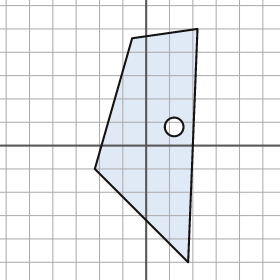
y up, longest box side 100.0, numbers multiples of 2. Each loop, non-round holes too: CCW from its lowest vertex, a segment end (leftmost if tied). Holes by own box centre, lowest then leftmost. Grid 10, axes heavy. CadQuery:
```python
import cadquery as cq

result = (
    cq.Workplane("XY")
    .moveTo(18.0, -50.0)
    .lineTo(22.0, 50.0)
    .lineTo(-6.0, 46.0)
    .lineTo(-22.0, -10.0)
    .close()
    .moveTo(12.0, 8.0)
    .circle(4.0)
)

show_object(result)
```